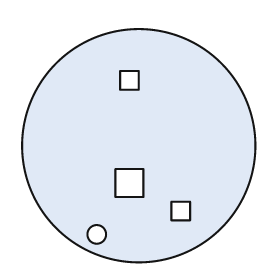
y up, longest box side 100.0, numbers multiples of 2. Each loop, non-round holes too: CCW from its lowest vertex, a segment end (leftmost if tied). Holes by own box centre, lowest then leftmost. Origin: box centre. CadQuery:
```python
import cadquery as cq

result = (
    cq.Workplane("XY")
    .moveTo(0.0, 0.0)
    .circle(50.0)
    .moveTo(-18.0, -38.0)
    .circle(4.0)
    .moveTo(14.0, -32.0)
    .lineTo(22.0, -32.0)
    .lineTo(22.0, -24.0)
    .lineTo(14.0, -24.0)
    .close()
    .moveTo(-10.0, -22.0)
    .lineTo(2.0, -22.0)
    .lineTo(2.0, -10.0)
    .lineTo(-10.0, -10.0)
    .close()
    .moveTo(-8.0, 24.0)
    .lineTo(0.0, 24.0)
    .lineTo(0.0, 32.0)
    .lineTo(-8.0, 32.0)
    .close()
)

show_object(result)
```